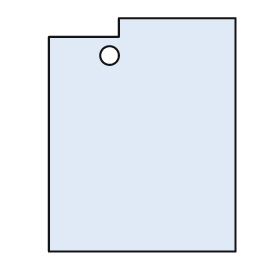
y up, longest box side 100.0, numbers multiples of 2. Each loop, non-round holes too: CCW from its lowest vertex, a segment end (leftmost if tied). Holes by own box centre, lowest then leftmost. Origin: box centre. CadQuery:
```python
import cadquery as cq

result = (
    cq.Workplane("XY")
    .moveTo(-40.0, -50.0)
    .lineTo(40.0, -50.0)
    .lineTo(40.0, 50.0)
    .lineTo(-10.0, 50.0)
    .lineTo(-10.0, 42.0)
    .lineTo(-40.0, 42.0)
    .close()
    .moveTo(-14.0, 34.0)
    .circle(4.0)
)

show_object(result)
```